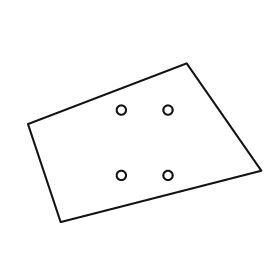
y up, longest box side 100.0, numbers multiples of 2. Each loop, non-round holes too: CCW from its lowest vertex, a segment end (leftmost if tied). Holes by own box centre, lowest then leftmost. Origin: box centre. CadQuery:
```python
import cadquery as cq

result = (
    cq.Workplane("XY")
    .moveTo(-36.0, -34.0)
    .lineTo(50.0, -12.0)
    .lineTo(18.0, 34.0)
    .lineTo(-50.0, 8.0)
    .close()
    .moveTo(-10.0, -14.0)
    .circle(2.0)
    .moveTo(10.0, -14.0)
    .circle(2.0)
    .moveTo(-10.0, 14.0)
    .circle(2.0)
    .moveTo(10.0, 14.0)
    .circle(2.0)
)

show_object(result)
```